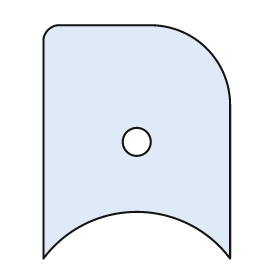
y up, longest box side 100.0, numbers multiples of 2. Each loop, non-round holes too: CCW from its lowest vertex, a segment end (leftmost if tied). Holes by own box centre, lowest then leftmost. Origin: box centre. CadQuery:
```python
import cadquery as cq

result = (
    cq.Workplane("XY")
    .moveTo(-40.0, -50.0)
    .threePointArc((0.0, -30.0), (40.0, -50.0))
    .lineTo(40.0, 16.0)
    .threePointArc((30.0, 40.0), (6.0, 50.0))
    .lineTo(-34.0, 50.0)
    .threePointArc((-38.0, 48.0), (-40.0, 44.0))
    .close()
    .moveTo(0.0, 0.0)
    .circle(6.0)
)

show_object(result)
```